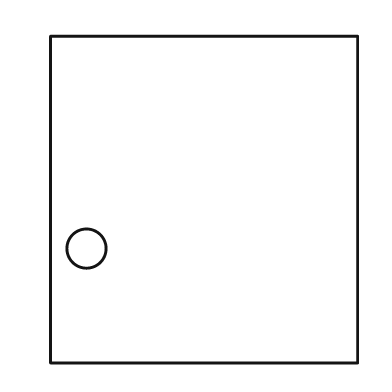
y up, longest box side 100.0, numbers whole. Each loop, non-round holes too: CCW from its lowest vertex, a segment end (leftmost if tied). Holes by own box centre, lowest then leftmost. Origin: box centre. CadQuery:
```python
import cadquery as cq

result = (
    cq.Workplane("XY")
    .moveTo(-47.0, -50.0)
    .lineTo(47.0, -50.0)
    .lineTo(47.0, 50.0)
    .lineTo(-47.0, 50.0)
    .close()
    .moveTo(-36.0, -15.0)
    .circle(6.0)
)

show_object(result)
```